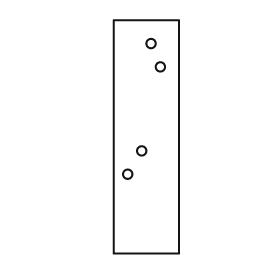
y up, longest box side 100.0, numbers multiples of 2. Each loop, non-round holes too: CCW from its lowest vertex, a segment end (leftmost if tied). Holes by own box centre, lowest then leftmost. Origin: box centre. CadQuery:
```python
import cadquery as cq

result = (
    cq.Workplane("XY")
    .moveTo(-14.0, -50.0)
    .lineTo(14.0, -50.0)
    .lineTo(14.0, 50.0)
    .lineTo(-14.0, 50.0)
    .close()
    .moveTo(-8.0, -16.0)
    .circle(2.0)
    .moveTo(-2.0, -6.0)
    .circle(2.0)
    .moveTo(6.0, 30.0)
    .circle(2.0)
    .moveTo(2.0, 40.0)
    .circle(2.0)
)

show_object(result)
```